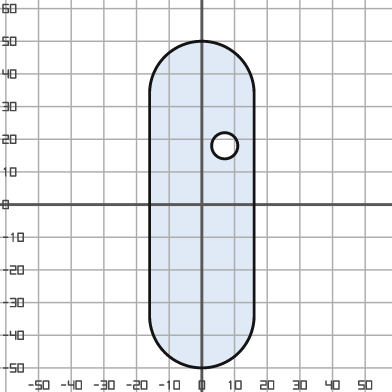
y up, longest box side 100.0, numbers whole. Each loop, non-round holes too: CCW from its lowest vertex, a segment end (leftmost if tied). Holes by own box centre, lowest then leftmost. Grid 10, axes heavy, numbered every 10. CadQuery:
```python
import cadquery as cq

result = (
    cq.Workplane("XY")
    .moveTo(-16.0, -34.0)
    .threePointArc((0.0, -50.0), (16.0, -34.0))
    .lineTo(16.0, 34.0)
    .threePointArc((0.0, 50.0), (-16.0, 34.0))
    .close()
    .moveTo(7.0, 18.0)
    .circle(4.0)
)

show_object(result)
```